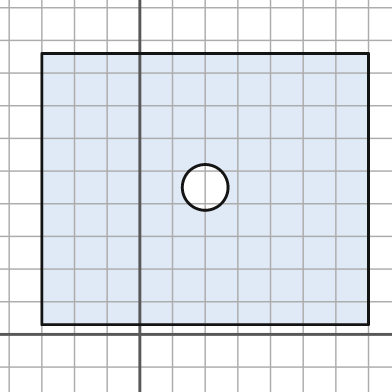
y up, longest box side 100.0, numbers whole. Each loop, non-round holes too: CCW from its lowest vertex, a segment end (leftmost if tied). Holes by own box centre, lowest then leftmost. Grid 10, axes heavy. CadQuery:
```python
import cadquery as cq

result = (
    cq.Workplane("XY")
    .moveTo(-30.0, 3.0)
    .lineTo(70.0, 3.0)
    .lineTo(70.0, 86.0)
    .lineTo(-30.0, 86.0)
    .close()
    .moveTo(20.0, 45.0)
    .circle(7.0)
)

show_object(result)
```